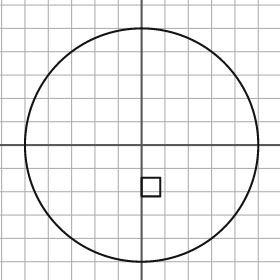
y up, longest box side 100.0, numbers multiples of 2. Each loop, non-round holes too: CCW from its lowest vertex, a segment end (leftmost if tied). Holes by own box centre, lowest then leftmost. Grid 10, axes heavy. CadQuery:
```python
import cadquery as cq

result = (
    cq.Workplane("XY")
    .moveTo(0.0, 0.0)
    .circle(50.0)
    .moveTo(0.0, -22.0)
    .lineTo(8.0, -22.0)
    .lineTo(8.0, -14.0)
    .lineTo(0.0, -14.0)
    .close()
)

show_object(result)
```